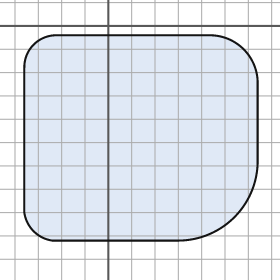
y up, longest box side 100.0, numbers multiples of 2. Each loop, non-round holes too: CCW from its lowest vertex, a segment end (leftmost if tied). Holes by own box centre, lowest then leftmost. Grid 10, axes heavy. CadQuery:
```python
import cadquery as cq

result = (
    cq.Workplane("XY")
    .moveTo(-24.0, -92.0)
    .lineTo(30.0, -92.0)
    .threePointArc((54.0, -82.0), (64.0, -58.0))
    .lineTo(64.0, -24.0)
    .threePointArc((58.0, -10.0), (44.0, -4.0))
    .lineTo(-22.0, -4.0)
    .threePointArc((-32.0, -8.0), (-36.0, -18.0))
    .lineTo(-36.0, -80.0)
    .threePointArc((-32.0, -88.0), (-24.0, -92.0))
    .close()
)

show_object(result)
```